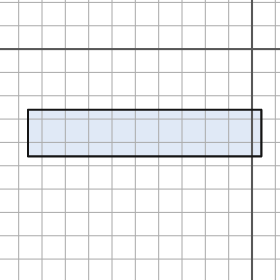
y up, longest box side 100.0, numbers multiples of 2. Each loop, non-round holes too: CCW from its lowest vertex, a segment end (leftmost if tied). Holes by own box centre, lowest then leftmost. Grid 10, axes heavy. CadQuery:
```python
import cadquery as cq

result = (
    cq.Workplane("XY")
    .moveTo(-96.0, -46.0)
    .lineTo(4.0, -46.0)
    .lineTo(4.0, -26.0)
    .lineTo(-96.0, -26.0)
    .close()
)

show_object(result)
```